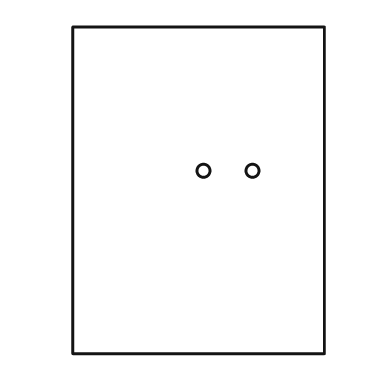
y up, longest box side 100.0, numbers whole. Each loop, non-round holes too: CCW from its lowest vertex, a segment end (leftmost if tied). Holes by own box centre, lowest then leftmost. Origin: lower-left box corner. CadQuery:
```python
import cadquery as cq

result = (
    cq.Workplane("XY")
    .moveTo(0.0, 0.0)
    .lineTo(77.0, 0.0)
    .lineTo(77.0, 100.0)
    .lineTo(0.0, 100.0)
    .close()
    .moveTo(40.0, 56.0)
    .circle(2.0)
    .moveTo(55.0, 56.0)
    .circle(2.0)
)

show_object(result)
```